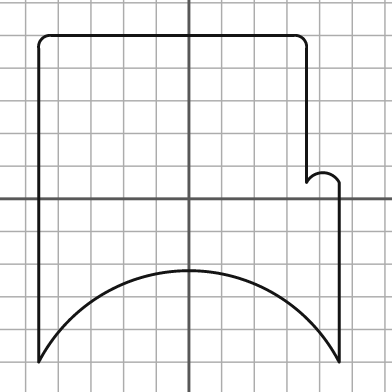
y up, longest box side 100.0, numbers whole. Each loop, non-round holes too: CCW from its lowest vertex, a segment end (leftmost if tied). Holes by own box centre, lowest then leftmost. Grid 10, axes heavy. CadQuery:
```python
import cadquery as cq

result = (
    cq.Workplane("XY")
    .moveTo(-46.0, -50.0)
    .threePointArc((0.0, -22.0), (46.0, -50.0))
    .lineTo(46.0, 5.0)
    .threePointArc((41.0, 8.0), (36.0, 5.0))
    .lineTo(36.0, 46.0)
    .threePointArc((35.0, 49.0), (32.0, 50.0))
    .lineTo(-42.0, 50.0)
    .threePointArc((-45.0, 49.0), (-46.0, 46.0))
    .close()
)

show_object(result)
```